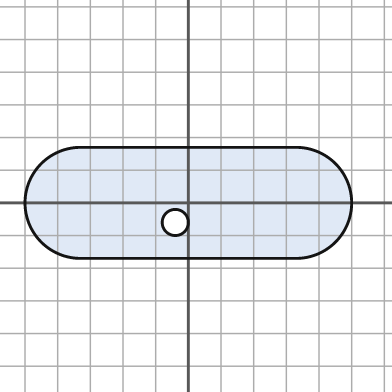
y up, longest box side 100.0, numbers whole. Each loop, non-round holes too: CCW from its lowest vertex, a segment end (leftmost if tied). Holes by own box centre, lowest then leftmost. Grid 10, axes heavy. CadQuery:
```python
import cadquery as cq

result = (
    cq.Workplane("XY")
    .moveTo(-33.0, -17.0)
    .lineTo(33.0, -17.0)
    .threePointArc((50.0, 0.0), (33.0, 17.0))
    .lineTo(-33.0, 17.0)
    .threePointArc((-50.0, 0.0), (-33.0, -17.0))
    .close()
    .moveTo(-4.0, -6.0)
    .circle(4.0)
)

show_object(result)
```